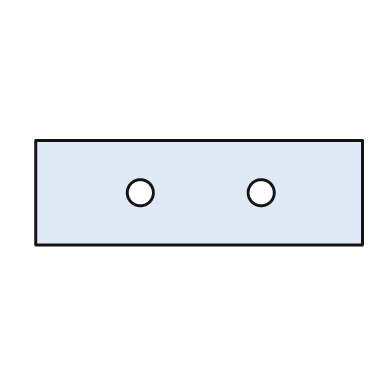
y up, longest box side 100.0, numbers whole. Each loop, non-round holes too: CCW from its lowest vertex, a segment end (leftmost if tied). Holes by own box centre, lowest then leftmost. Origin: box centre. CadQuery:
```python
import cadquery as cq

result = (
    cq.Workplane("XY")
    .moveTo(-50.0, -16.0)
    .lineTo(50.0, -16.0)
    .lineTo(50.0, 16.0)
    .lineTo(-50.0, 16.0)
    .close()
    .moveTo(-18.0, 0.0)
    .circle(4.0)
    .moveTo(19.0, 0.0)
    .circle(4.0)
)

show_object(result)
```